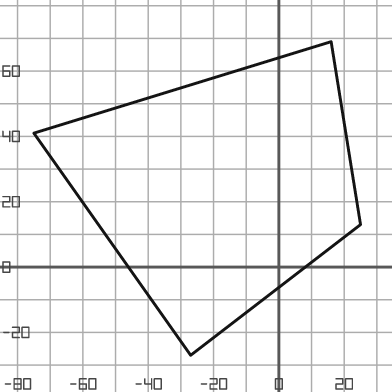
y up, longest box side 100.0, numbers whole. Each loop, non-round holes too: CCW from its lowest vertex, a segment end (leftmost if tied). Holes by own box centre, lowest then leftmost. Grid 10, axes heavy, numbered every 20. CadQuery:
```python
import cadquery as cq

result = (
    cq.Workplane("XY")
    .moveTo(-27.0, -27.0)
    .lineTo(25.0, 13.0)
    .lineTo(16.0, 69.0)
    .lineTo(-75.0, 41.0)
    .close()
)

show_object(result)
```